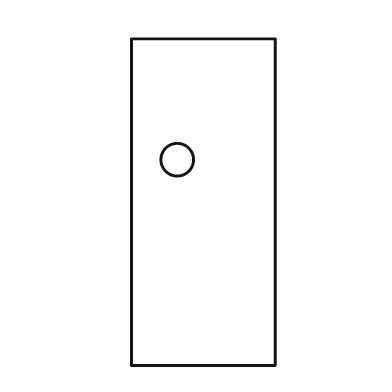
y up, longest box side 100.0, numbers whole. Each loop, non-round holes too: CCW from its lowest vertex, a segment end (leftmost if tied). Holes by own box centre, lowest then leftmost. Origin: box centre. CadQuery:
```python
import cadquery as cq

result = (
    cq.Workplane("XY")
    .moveTo(-22.0, -50.0)
    .lineTo(22.0, -50.0)
    .lineTo(22.0, 50.0)
    .lineTo(-22.0, 50.0)
    .close()
    .moveTo(-8.0, 13.0)
    .circle(5.0)
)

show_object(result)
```